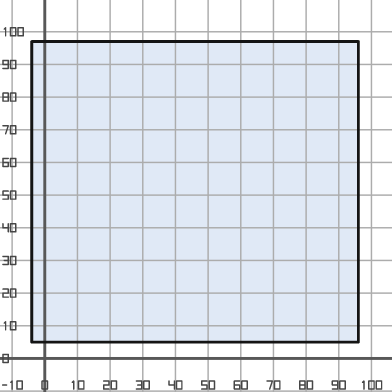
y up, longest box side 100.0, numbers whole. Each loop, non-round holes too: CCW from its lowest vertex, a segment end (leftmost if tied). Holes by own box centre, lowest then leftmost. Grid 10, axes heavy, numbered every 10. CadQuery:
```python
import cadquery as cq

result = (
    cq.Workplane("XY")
    .moveTo(-4.0, 5.0)
    .lineTo(96.0, 5.0)
    .lineTo(96.0, 97.0)
    .lineTo(-4.0, 97.0)
    .close()
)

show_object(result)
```